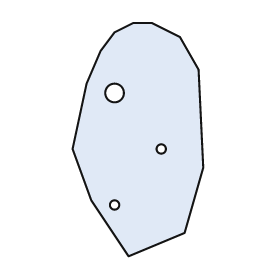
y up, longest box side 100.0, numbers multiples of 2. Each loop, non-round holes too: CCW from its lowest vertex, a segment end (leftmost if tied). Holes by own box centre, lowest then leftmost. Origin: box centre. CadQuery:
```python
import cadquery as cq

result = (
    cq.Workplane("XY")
    .moveTo(-4.0, -50.0)
    .lineTo(20.0, -40.0)
    .lineTo(28.0, -12.0)
    .lineTo(26.0, 30.0)
    .lineTo(18.0, 44.0)
    .lineTo(6.0, 50.0)
    .lineTo(-2.0, 50.0)
    .lineTo(-10.0, 46.0)
    .lineTo(-16.0, 38.0)
    .lineTo(-22.0, 24.0)
    .lineTo(-28.0, -4.0)
    .lineTo(-20.0, -26.0)
    .close()
    .moveTo(-10.0, -28.0)
    .circle(2.0)
    .moveTo(10.0, -4.0)
    .circle(2.0)
    .moveTo(-10.0, 20.0)
    .circle(4.0)
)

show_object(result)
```